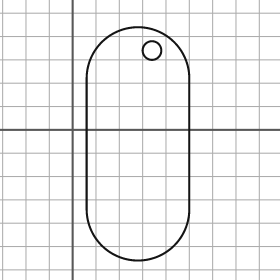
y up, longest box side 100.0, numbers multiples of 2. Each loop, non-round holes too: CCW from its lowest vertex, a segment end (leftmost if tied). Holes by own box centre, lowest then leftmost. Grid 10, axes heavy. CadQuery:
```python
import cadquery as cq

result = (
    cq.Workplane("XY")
    .moveTo(6.0, -34.0)
    .threePointArc((28.0, -56.0), (50.0, -34.0))
    .lineTo(50.0, 22.0)
    .threePointArc((28.0, 44.0), (6.0, 22.0))
    .close()
    .moveTo(34.0, 34.0)
    .circle(4.0)
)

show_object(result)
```